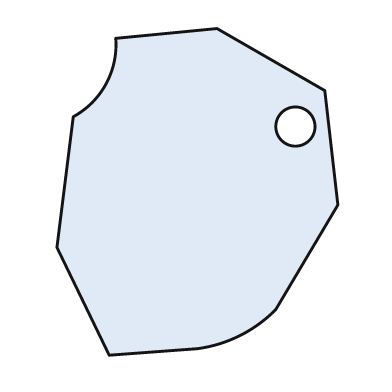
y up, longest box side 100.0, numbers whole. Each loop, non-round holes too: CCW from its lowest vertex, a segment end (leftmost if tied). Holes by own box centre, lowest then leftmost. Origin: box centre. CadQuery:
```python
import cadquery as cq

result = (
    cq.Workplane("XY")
    .moveTo(-27.0, -50.0)
    .lineTo(0.0, -48.0)
    .threePointArc((13.0, -44.0), (24.0, -36.0))
    .lineTo(43.0, -4.0)
    .lineTo(39.0, 31.0)
    .lineTo(6.0, 50.0)
    .lineTo(-25.0, 47.0)
    .threePointArc((-28.0, 33.0), (-38.0, 23.0))
    .lineTo(-43.0, -17.0)
    .close()
    .moveTo(30.0, 20.0)
    .circle(6.0)
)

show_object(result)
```